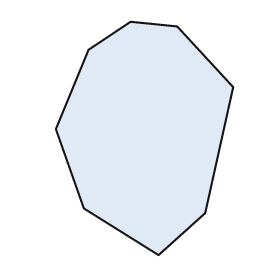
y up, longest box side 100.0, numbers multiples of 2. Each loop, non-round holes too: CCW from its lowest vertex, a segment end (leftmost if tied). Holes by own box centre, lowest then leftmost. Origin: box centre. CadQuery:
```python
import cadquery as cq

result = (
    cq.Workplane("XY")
    .moveTo(6.0, -50.0)
    .lineTo(26.0, -32.0)
    .lineTo(38.0, 22.0)
    .lineTo(14.0, 48.0)
    .lineTo(-6.0, 50.0)
    .lineTo(-24.0, 38.0)
    .lineTo(-38.0, 4.0)
    .lineTo(-26.0, -30.0)
    .close()
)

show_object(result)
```